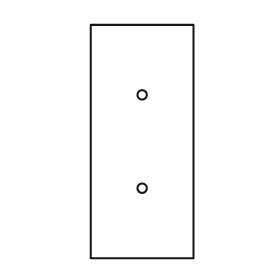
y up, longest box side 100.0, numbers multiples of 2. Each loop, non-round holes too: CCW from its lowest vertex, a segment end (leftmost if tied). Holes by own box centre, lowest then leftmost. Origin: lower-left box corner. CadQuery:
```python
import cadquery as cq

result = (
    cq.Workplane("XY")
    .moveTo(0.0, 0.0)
    .lineTo(44.0, 0.0)
    .lineTo(44.0, 100.0)
    .lineTo(0.0, 100.0)
    .close()
    .moveTo(22.0, 30.0)
    .circle(2.0)
    .moveTo(22.0, 70.0)
    .circle(2.0)
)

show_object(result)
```